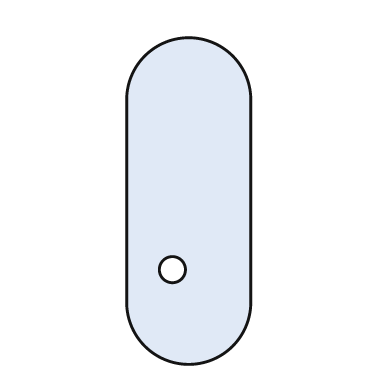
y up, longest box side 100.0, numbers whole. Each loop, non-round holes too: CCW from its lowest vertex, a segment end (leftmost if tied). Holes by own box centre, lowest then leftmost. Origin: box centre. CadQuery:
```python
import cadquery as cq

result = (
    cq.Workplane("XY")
    .moveTo(-19.0, -31.0)
    .threePointArc((0.0, -50.0), (19.0, -31.0))
    .lineTo(19.0, 31.0)
    .threePointArc((0.0, 50.0), (-19.0, 31.0))
    .close()
    .moveTo(-5.0, -21.0)
    .circle(4.0)
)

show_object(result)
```